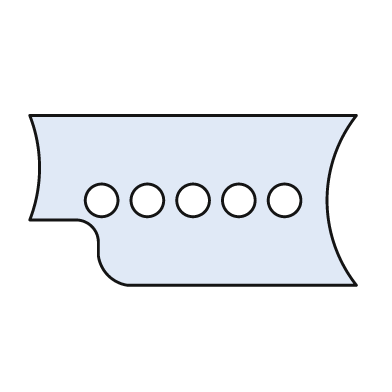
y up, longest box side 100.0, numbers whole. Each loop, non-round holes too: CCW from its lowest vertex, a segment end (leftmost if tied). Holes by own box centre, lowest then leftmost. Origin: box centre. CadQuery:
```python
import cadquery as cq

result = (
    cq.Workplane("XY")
    .moveTo(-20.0, -26.0)
    .lineTo(50.0, -26.0)
    .threePointArc((41.0, 0.0), (50.0, 26.0))
    .lineTo(-50.0, 26.0)
    .threePointArc((-47.0, 10.0), (-50.0, -6.0))
    .lineTo(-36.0, -6.0)
    .threePointArc((-31.0, -8.0), (-29.0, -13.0))
    .lineTo(-29.0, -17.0)
    .threePointArc((-26.0, -23.0), (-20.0, -26.0))
    .close()
    .moveTo(-28.0, 0.0)
    .circle(5.0)
    .moveTo(-14.0, 0.0)
    .circle(5.0)
    .moveTo(0.0, 0.0)
    .circle(5.0)
    .moveTo(14.0, 0.0)
    .circle(5.0)
    .moveTo(28.0, 0.0)
    .circle(5.0)
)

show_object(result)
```